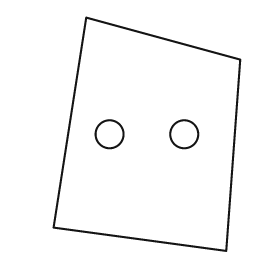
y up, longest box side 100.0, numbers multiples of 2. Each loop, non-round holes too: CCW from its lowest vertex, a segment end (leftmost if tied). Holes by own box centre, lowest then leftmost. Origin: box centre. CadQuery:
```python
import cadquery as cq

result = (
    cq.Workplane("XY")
    .moveTo(34.0, -50.0)
    .lineTo(40.0, 32.0)
    .lineTo(-26.0, 50.0)
    .lineTo(-40.0, -40.0)
    .close()
    .moveTo(-16.0, 0.0)
    .circle(6.0)
    .moveTo(16.0, 0.0)
    .circle(6.0)
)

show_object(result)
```